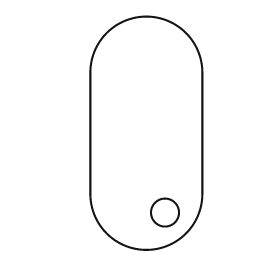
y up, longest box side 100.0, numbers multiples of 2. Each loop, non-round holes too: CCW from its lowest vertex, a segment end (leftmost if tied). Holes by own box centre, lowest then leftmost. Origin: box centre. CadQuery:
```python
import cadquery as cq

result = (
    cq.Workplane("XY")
    .moveTo(-24.0, -26.0)
    .threePointArc((0.0, -50.0), (24.0, -26.0))
    .lineTo(24.0, 26.0)
    .threePointArc((0.0, 50.0), (-24.0, 26.0))
    .close()
    .moveTo(8.0, -34.0)
    .circle(6.0)
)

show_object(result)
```